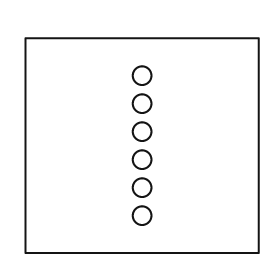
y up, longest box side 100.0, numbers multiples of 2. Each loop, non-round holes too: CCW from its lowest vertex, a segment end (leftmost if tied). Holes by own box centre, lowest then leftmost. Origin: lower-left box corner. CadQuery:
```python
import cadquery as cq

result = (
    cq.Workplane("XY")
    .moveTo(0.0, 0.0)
    .lineTo(100.0, 0.0)
    .lineTo(100.0, 92.0)
    .lineTo(0.0, 92.0)
    .close()
    .moveTo(50.0, 16.0)
    .circle(4.0)
    .moveTo(50.0, 28.0)
    .circle(4.0)
    .moveTo(50.0, 40.0)
    .circle(4.0)
    .moveTo(50.0, 52.0)
    .circle(4.0)
    .moveTo(50.0, 64.0)
    .circle(4.0)
    .moveTo(50.0, 76.0)
    .circle(4.0)
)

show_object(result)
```